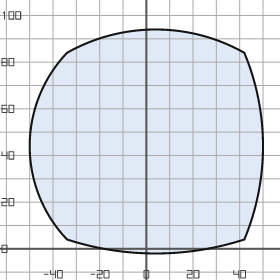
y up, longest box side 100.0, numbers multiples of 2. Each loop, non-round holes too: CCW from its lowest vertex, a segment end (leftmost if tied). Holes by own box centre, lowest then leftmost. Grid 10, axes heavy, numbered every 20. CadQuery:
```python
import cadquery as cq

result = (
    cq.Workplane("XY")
    .moveTo(-34.0, 4.0)
    .threePointArc((4.0, -2.0), (42.0, 4.0))
    .threePointArc((50.0, 44.0), (42.0, 84.0))
    .threePointArc((4.0, 94.0), (-34.0, 84.0))
    .threePointArc((-50.0, 44.0), (-34.0, 4.0))
    .close()
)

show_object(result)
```